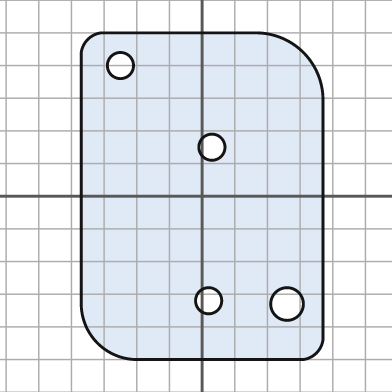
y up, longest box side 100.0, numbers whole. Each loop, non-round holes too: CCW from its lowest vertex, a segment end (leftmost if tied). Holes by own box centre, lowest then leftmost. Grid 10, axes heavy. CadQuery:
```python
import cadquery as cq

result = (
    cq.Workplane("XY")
    .moveTo(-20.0, -50.0)
    .lineTo(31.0, -50.0)
    .threePointArc((35.0, -48.0), (37.0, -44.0))
    .lineTo(37.0, 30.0)
    .threePointArc((31.0, 44.0), (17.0, 50.0))
    .lineTo(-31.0, 50.0)
    .threePointArc((-35.0, 48.0), (-37.0, 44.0))
    .lineTo(-37.0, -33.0)
    .threePointArc((-32.0, -45.0), (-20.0, -50.0))
    .close()
    .moveTo(26.0, -33.0)
    .circle(5.0)
    .moveTo(2.0, -32.0)
    .circle(4.0)
    .moveTo(3.0, 15.0)
    .circle(4.0)
    .moveTo(-25.0, 40.0)
    .circle(4.0)
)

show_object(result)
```